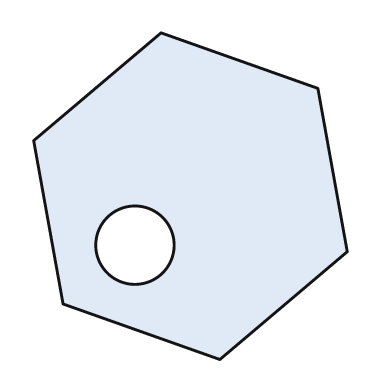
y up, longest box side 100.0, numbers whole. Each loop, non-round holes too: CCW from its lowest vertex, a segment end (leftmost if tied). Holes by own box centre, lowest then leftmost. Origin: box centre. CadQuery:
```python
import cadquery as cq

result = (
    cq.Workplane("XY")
    .moveTo(9.0, -50.0)
    .lineTo(48.0, -17.0)
    .lineTo(39.0, 33.0)
    .lineTo(-9.0, 50.0)
    .lineTo(-48.0, 17.0)
    .lineTo(-39.0, -33.0)
    .close()
    .moveTo(-17.0, -15.0)
    .circle(12.0)
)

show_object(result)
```